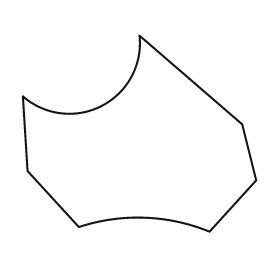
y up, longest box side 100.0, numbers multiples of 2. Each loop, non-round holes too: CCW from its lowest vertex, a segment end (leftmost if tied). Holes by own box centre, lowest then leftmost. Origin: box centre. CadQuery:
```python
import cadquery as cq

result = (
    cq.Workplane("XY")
    .moveTo(30.0, -42.0)
    .lineTo(50.0, -20.0)
    .lineTo(44.0, 4.0)
    .lineTo(0.0, 42.0)
    .threePointArc((-16.0, 12.0), (-50.0, 16.0))
    .lineTo(-48.0, -16.0)
    .lineTo(-26.0, -40.0)
    .threePointArc((2.0, -36.0), (30.0, -42.0))
    .close()
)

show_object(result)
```